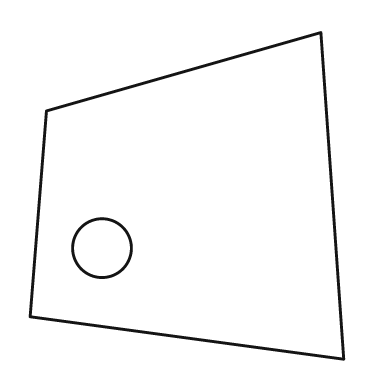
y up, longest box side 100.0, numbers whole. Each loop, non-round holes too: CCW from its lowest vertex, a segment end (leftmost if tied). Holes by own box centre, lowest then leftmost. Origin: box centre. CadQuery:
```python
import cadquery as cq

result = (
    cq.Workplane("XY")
    .moveTo(48.0, -50.0)
    .lineTo(41.0, 50.0)
    .lineTo(-43.0, 26.0)
    .lineTo(-48.0, -37.0)
    .close()
    .moveTo(-26.0, -16.0)
    .circle(9.0)
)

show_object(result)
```